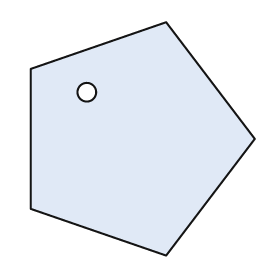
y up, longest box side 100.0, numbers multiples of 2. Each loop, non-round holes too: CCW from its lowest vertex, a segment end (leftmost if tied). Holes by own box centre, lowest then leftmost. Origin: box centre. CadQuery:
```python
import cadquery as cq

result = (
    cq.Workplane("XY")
    .moveTo(10.0, -50.0)
    .lineTo(48.0, 0.0)
    .lineTo(10.0, 50.0)
    .lineTo(-48.0, 30.0)
    .lineTo(-48.0, -30.0)
    .close()
    .moveTo(-24.0, 20.0)
    .circle(4.0)
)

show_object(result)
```